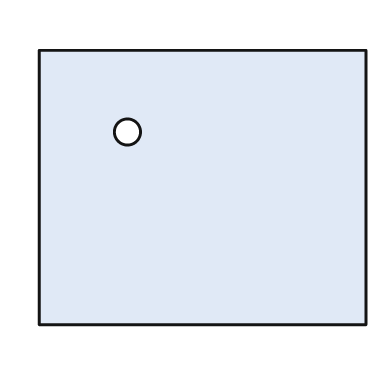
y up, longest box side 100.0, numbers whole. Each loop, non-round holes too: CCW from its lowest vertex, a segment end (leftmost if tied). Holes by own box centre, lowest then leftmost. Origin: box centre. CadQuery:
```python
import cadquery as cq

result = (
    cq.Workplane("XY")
    .moveTo(-50.0, -42.0)
    .lineTo(50.0, -42.0)
    .lineTo(50.0, 42.0)
    .lineTo(-50.0, 42.0)
    .close()
    .moveTo(-23.0, 17.0)
    .circle(4.0)
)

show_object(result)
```